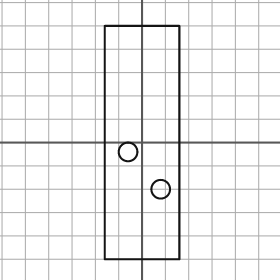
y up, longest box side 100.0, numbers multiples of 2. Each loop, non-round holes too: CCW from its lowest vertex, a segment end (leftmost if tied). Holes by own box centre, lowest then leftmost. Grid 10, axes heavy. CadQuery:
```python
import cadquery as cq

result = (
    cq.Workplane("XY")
    .moveTo(-16.0, -50.0)
    .lineTo(16.0, -50.0)
    .lineTo(16.0, 50.0)
    .lineTo(-16.0, 50.0)
    .close()
    .moveTo(8.0, -20.0)
    .circle(4.0)
    .moveTo(-6.0, -4.0)
    .circle(4.0)
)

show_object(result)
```